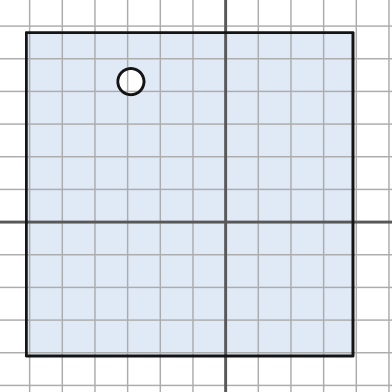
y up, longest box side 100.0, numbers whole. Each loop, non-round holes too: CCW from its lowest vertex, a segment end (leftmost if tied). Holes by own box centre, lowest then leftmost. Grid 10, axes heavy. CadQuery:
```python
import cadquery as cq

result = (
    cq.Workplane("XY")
    .moveTo(-61.0, -41.0)
    .lineTo(39.0, -41.0)
    .lineTo(39.0, 58.0)
    .lineTo(-61.0, 58.0)
    .close()
    .moveTo(-29.0, 43.0)
    .circle(4.0)
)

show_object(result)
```